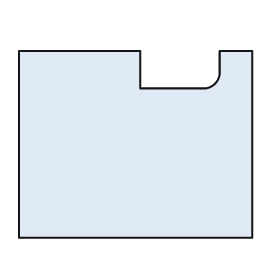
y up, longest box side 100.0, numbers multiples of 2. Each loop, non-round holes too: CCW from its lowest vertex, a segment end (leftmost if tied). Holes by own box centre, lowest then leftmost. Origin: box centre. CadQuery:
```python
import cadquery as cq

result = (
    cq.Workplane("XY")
    .moveTo(-50.0, -40.0)
    .lineTo(50.0, -40.0)
    .lineTo(50.0, 40.0)
    .lineTo(36.0, 40.0)
    .lineTo(36.0, 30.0)
    .threePointArc((34.0, 26.0), (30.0, 24.0))
    .lineTo(2.0, 24.0)
    .lineTo(2.0, 40.0)
    .lineTo(-50.0, 40.0)
    .close()
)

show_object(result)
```